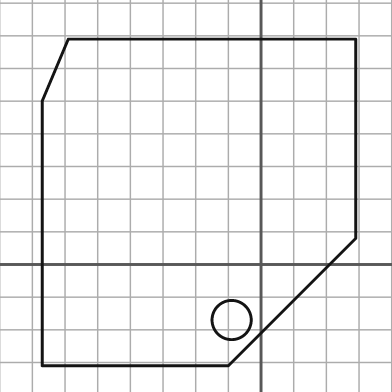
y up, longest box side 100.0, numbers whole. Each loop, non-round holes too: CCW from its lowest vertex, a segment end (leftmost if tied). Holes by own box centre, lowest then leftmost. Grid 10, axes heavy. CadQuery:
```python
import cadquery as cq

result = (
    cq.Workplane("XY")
    .moveTo(-67.0, -31.0)
    .lineTo(-10.0, -31.0)
    .lineTo(29.0, 8.0)
    .lineTo(29.0, 69.0)
    .lineTo(-59.0, 69.0)
    .lineTo(-67.0, 50.0)
    .close()
    .moveTo(-9.0, -17.0)
    .circle(6.0)
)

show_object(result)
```